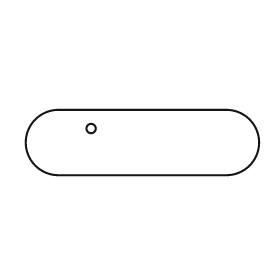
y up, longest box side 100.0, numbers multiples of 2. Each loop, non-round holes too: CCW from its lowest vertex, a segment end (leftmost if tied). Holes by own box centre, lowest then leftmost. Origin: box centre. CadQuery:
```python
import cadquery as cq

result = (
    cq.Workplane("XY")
    .moveTo(-36.0, -14.0)
    .lineTo(36.0, -14.0)
    .threePointArc((50.0, 0.0), (36.0, 14.0))
    .lineTo(-36.0, 14.0)
    .threePointArc((-50.0, 0.0), (-36.0, -14.0))
    .close()
    .moveTo(-22.0, 6.0)
    .circle(2.0)
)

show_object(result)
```